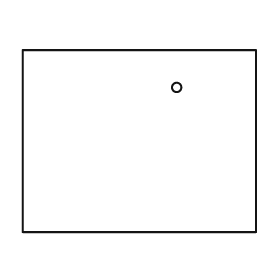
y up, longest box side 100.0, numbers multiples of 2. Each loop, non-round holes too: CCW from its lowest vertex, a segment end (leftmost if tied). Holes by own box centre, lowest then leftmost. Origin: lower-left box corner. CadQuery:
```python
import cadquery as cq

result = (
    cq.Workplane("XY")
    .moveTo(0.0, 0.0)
    .lineTo(100.0, 0.0)
    .lineTo(100.0, 78.0)
    .lineTo(0.0, 78.0)
    .close()
    .moveTo(66.0, 62.0)
    .circle(2.0)
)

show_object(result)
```